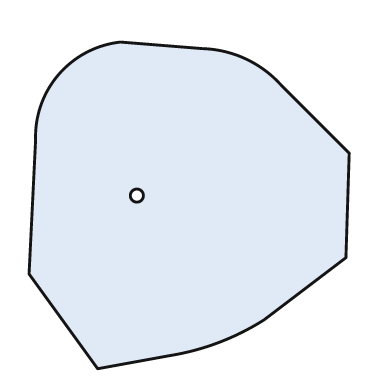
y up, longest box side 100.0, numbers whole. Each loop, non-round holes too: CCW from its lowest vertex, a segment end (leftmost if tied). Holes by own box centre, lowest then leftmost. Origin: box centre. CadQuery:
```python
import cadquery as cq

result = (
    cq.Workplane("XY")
    .moveTo(-28.0, -50.0)
    .lineTo(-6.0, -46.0)
    .threePointArc((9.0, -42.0), (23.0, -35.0))
    .lineTo(48.0, -16.0)
    .lineTo(49.0, 16.0)
    .lineTo(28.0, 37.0)
    .threePointArc((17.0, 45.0), (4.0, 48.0))
    .lineTo(-21.0, 50.0)
    .threePointArc((-40.0, 40.0), (-47.0, 20.0))
    .lineTo(-49.0, -21.0)
    .close()
    .moveTo(-16.0, 3.0)
    .circle(2.0)
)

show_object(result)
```